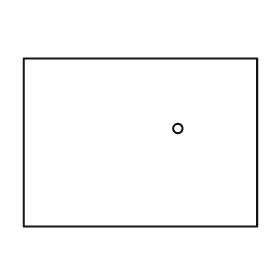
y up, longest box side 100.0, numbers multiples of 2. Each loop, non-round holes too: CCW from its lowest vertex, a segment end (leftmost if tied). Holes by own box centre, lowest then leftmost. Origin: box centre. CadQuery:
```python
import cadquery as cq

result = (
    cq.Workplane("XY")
    .moveTo(-50.0, -36.0)
    .lineTo(50.0, -36.0)
    .lineTo(50.0, 36.0)
    .lineTo(-50.0, 36.0)
    .close()
    .moveTo(16.0, 6.0)
    .circle(2.0)
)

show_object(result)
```